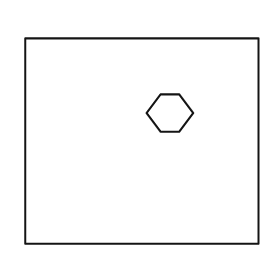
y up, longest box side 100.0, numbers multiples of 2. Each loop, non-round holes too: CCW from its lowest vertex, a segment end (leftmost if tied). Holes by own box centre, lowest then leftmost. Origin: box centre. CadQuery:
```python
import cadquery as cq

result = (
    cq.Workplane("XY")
    .moveTo(-50.0, -44.0)
    .lineTo(50.0, -44.0)
    .lineTo(50.0, 44.0)
    .lineTo(-50.0, 44.0)
    .close()
    .moveTo(8.0, 4.0)
    .lineTo(16.0, 4.0)
    .lineTo(22.0, 12.0)
    .lineTo(16.0, 20.0)
    .lineTo(8.0, 20.0)
    .lineTo(2.0, 12.0)
    .close()
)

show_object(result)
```